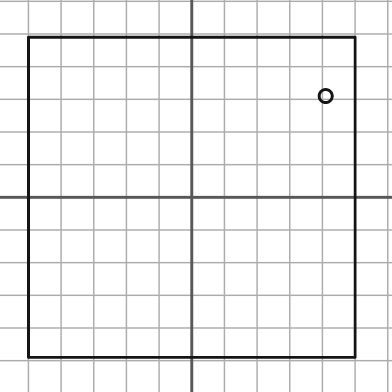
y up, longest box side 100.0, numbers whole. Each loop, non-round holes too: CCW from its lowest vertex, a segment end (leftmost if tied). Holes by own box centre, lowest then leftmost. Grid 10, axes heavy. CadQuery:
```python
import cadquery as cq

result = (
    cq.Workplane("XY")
    .moveTo(-50.0, -49.0)
    .lineTo(50.0, -49.0)
    .lineTo(50.0, 49.0)
    .lineTo(-50.0, 49.0)
    .close()
    .moveTo(41.0, 31.0)
    .circle(2.0)
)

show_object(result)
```